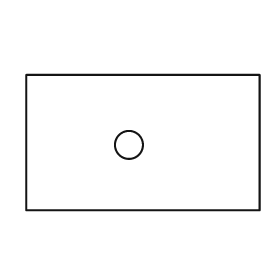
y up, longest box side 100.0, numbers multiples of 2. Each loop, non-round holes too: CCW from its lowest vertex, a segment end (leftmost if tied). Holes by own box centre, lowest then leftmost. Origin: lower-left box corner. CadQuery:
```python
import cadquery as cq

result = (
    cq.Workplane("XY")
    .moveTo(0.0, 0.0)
    .lineTo(100.0, 0.0)
    .lineTo(100.0, 58.0)
    .lineTo(0.0, 58.0)
    .close()
    .moveTo(44.0, 28.0)
    .circle(6.0)
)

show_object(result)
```